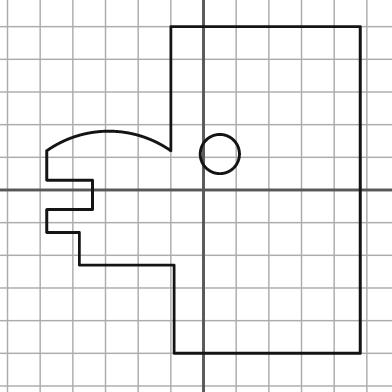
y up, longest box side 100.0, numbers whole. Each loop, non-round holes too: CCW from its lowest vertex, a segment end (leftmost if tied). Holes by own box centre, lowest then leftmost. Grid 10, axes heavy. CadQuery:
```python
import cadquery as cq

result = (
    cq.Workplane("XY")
    .moveTo(-9.0, -50.0)
    .lineTo(48.0, -50.0)
    .lineTo(48.0, 50.0)
    .lineTo(-10.0, 50.0)
    .lineTo(-10.0, 12.0)
    .threePointArc((-29.0, 18.0), (-48.0, 12.0))
    .lineTo(-48.0, 3.0)
    .lineTo(-34.0, 3.0)
    .lineTo(-34.0, -6.0)
    .lineTo(-48.0, -6.0)
    .lineTo(-48.0, -13.0)
    .lineTo(-38.0, -13.0)
    .lineTo(-38.0, -23.0)
    .lineTo(-9.0, -23.0)
    .close()
    .moveTo(5.0, 11.0)
    .circle(6.0)
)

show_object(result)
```